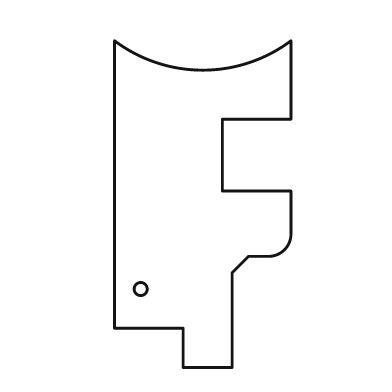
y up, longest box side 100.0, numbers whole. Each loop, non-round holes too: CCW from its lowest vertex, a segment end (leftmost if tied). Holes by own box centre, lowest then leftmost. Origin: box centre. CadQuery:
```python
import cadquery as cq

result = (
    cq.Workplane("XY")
    .moveTo(-6.0, -50.0)
    .lineTo(9.0, -50.0)
    .lineTo(9.0, -21.0)
    .lineTo(14.0, -16.0)
    .lineTo(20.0, -16.0)
    .threePointArc((25.0, -14.0), (27.0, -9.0))
    .lineTo(27.0, 4.0)
    .lineTo(6.0, 4.0)
    .lineTo(6.0, 26.0)
    .lineTo(27.0, 26.0)
    .lineTo(27.0, 50.0)
    .threePointArc((0.0, 41.0), (-27.0, 50.0))
    .lineTo(-27.0, -38.0)
    .lineTo(-6.0, -38.0)
    .close()
    .moveTo(-19.0, -26.0)
    .circle(2.0)
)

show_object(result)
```